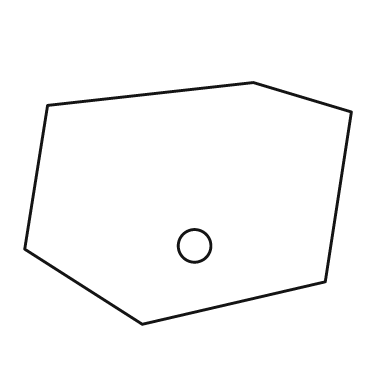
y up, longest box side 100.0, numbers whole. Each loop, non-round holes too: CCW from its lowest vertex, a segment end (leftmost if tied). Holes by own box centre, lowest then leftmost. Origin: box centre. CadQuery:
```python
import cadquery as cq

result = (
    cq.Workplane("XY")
    .moveTo(-14.0, -37.0)
    .lineTo(42.0, -24.0)
    .lineTo(50.0, 28.0)
    .lineTo(20.0, 37.0)
    .lineTo(-43.0, 30.0)
    .lineTo(-50.0, -14.0)
    .close()
    .moveTo(2.0, -13.0)
    .circle(5.0)
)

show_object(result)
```